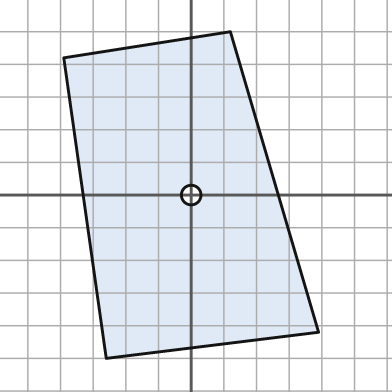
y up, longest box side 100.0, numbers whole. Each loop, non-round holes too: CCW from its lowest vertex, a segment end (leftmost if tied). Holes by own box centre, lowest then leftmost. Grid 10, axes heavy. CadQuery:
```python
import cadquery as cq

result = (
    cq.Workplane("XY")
    .moveTo(-26.0, -50.0)
    .lineTo(39.0, -42.0)
    .lineTo(12.0, 50.0)
    .lineTo(-39.0, 42.0)
    .close()
    .moveTo(0.0, 0.0)
    .circle(3.0)
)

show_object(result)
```